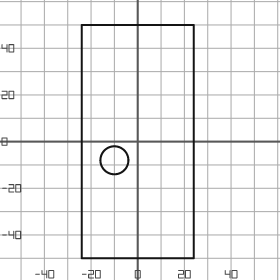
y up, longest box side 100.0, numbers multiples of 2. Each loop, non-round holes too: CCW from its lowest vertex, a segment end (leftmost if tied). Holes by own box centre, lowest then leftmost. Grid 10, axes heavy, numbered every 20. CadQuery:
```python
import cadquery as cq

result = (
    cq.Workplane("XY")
    .moveTo(-24.0, -50.0)
    .lineTo(24.0, -50.0)
    .lineTo(24.0, 50.0)
    .lineTo(-24.0, 50.0)
    .close()
    .moveTo(-10.0, -8.0)
    .circle(6.0)
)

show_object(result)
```